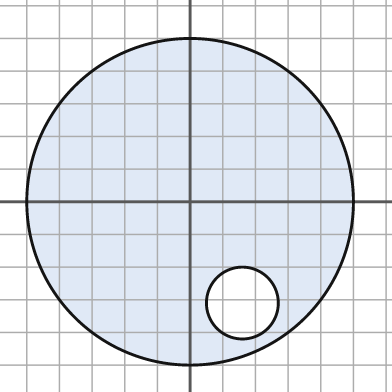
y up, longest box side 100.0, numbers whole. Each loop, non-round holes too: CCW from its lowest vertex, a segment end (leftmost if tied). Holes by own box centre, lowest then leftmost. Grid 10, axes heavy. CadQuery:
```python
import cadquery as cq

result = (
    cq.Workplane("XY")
    .moveTo(0.0, 0.0)
    .circle(50.0)
    .moveTo(16.0, -31.0)
    .circle(11.0)
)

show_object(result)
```